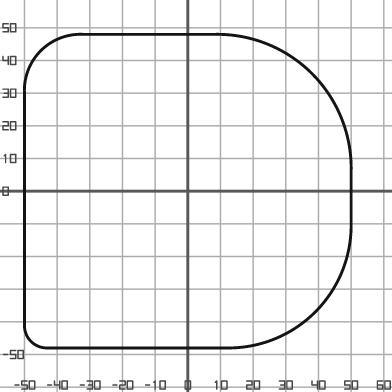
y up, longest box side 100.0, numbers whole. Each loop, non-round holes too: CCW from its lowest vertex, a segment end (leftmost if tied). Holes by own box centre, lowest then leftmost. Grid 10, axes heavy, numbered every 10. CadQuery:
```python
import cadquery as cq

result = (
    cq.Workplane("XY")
    .moveTo(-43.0, -48.0)
    .lineTo(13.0, -48.0)
    .threePointArc((39.0, -37.0), (50.0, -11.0))
    .lineTo(50.0, 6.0)
    .threePointArc((38.0, 36.0), (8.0, 48.0))
    .lineTo(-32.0, 48.0)
    .threePointArc((-45.0, 43.0), (-50.0, 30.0))
    .lineTo(-50.0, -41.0)
    .threePointArc((-48.0, -46.0), (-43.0, -48.0))
    .close()
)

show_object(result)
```